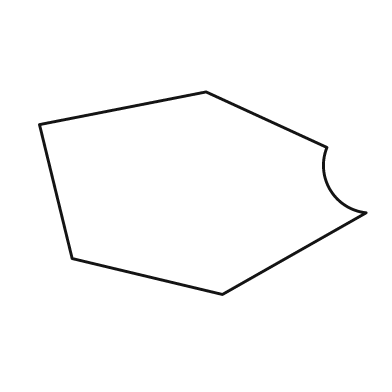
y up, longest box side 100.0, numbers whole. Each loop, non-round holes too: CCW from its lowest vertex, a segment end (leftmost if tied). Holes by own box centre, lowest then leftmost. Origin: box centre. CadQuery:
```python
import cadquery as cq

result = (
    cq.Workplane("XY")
    .moveTo(6.0, -31.0)
    .lineTo(50.0, -6.0)
    .threePointArc((39.0, 1.0), (38.0, 14.0))
    .lineTo(1.0, 31.0)
    .lineTo(-50.0, 21.0)
    .lineTo(-40.0, -20.0)
    .close()
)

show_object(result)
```